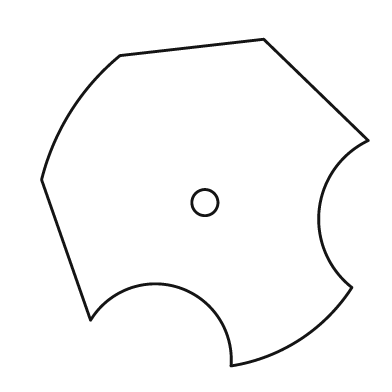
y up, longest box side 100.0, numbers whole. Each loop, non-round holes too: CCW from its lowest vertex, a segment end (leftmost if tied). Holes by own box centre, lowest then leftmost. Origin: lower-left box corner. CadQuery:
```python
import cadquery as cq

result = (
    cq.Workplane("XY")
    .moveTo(58.0, 0.0)
    .threePointArc((79.0, 8.0), (95.0, 24.0))
    .threePointArc((85.0, 48.0), (100.0, 69.0))
    .lineTo(68.0, 100.0)
    .lineTo(24.0, 95.0)
    .threePointArc((9.0, 78.0), (0.0, 57.0))
    .lineTo(15.0, 14.0)
    .threePointArc((42.0, 24.0), (58.0, 0.0))
    .close()
    .moveTo(50.0, 50.0)
    .circle(4.0)
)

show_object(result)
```